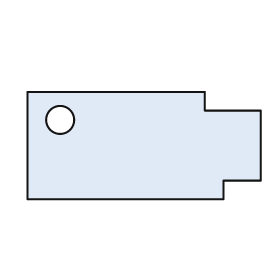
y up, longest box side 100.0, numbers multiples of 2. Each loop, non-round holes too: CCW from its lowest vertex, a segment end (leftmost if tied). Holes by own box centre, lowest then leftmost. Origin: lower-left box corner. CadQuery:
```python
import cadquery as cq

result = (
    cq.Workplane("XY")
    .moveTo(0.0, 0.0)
    .lineTo(84.0, 0.0)
    .lineTo(84.0, 8.0)
    .lineTo(100.0, 8.0)
    .lineTo(100.0, 38.0)
    .lineTo(76.0, 38.0)
    .lineTo(76.0, 46.0)
    .lineTo(0.0, 46.0)
    .close()
    .moveTo(14.0, 34.0)
    .circle(6.0)
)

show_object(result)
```